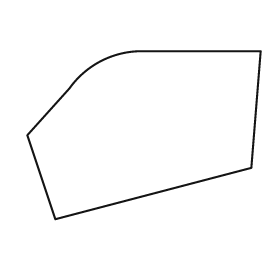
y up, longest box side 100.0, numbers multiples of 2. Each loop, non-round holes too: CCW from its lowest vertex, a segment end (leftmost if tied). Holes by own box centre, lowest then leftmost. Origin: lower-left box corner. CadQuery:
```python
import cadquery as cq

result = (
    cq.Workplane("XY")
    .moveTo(12.0, 0.0)
    .lineTo(96.0, 22.0)
    .lineTo(100.0, 72.0)
    .lineTo(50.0, 72.0)
    .threePointArc((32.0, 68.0), (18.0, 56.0))
    .lineTo(0.0, 36.0)
    .close()
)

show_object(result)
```